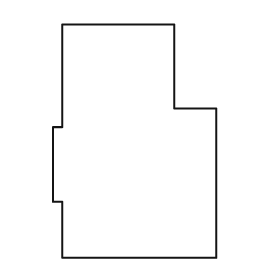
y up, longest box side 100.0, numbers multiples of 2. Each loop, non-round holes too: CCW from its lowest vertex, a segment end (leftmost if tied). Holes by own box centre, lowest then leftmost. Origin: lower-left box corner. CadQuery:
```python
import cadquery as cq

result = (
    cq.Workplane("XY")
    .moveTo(4.0, 0.0)
    .lineTo(70.0, 0.0)
    .lineTo(70.0, 64.0)
    .lineTo(52.0, 64.0)
    .lineTo(52.0, 100.0)
    .lineTo(4.0, 100.0)
    .lineTo(4.0, 56.0)
    .lineTo(0.0, 56.0)
    .lineTo(0.0, 24.0)
    .lineTo(4.0, 24.0)
    .close()
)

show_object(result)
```